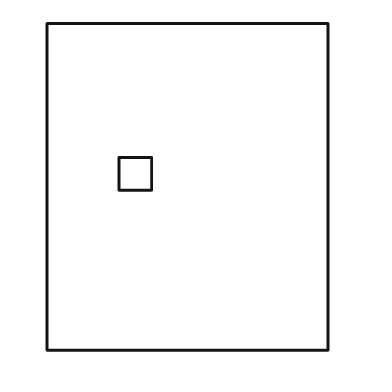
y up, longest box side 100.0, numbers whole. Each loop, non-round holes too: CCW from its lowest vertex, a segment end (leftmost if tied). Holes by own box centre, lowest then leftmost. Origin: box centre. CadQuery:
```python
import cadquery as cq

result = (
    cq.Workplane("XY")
    .moveTo(-43.0, -50.0)
    .lineTo(43.0, -50.0)
    .lineTo(43.0, 50.0)
    .lineTo(-43.0, 50.0)
    .close()
    .moveTo(-21.0, -1.0)
    .lineTo(-11.0, -1.0)
    .lineTo(-11.0, 9.0)
    .lineTo(-21.0, 9.0)
    .close()
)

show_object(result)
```